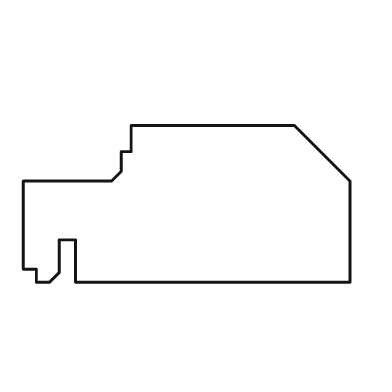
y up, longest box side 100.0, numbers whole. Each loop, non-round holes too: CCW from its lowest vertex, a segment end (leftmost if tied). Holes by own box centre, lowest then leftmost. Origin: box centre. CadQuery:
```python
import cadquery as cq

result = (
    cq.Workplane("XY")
    .moveTo(-46.0, -24.0)
    .lineTo(-42.0, -24.0)
    .lineTo(-39.0, -21.0)
    .lineTo(-39.0, -11.0)
    .lineTo(-34.0, -11.0)
    .lineTo(-34.0, -24.0)
    .lineTo(50.0, -24.0)
    .lineTo(50.0, 7.0)
    .lineTo(33.0, 24.0)
    .lineTo(-17.0, 24.0)
    .lineTo(-17.0, 16.0)
    .lineTo(-20.0, 16.0)
    .lineTo(-20.0, 10.0)
    .lineTo(-23.0, 7.0)
    .lineTo(-50.0, 7.0)
    .lineTo(-50.0, -20.0)
    .lineTo(-46.0, -20.0)
    .close()
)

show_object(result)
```